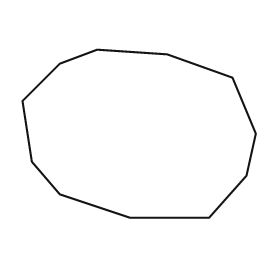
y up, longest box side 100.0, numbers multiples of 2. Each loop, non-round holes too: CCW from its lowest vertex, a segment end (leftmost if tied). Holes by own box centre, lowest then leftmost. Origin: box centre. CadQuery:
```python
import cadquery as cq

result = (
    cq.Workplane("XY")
    .moveTo(-4.0, -36.0)
    .lineTo(30.0, -36.0)
    .lineTo(46.0, -18.0)
    .lineTo(50.0, 0.0)
    .lineTo(40.0, 24.0)
    .lineTo(12.0, 34.0)
    .lineTo(-18.0, 36.0)
    .lineTo(-34.0, 30.0)
    .lineTo(-50.0, 14.0)
    .lineTo(-46.0, -12.0)
    .lineTo(-34.0, -26.0)
    .close()
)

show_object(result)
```